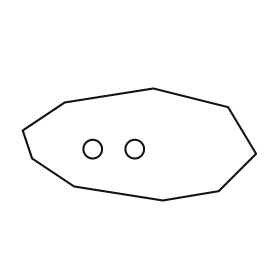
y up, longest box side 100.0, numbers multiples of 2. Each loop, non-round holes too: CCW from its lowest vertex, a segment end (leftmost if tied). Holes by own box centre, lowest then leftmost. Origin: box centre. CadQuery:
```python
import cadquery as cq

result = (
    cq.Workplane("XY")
    .moveTo(10.0, -24.0)
    .lineTo(34.0, -20.0)
    .lineTo(50.0, -4.0)
    .lineTo(38.0, 16.0)
    .lineTo(6.0, 24.0)
    .lineTo(-32.0, 18.0)
    .lineTo(-50.0, 6.0)
    .lineTo(-46.0, -6.0)
    .lineTo(-28.0, -18.0)
    .close()
    .moveTo(-20.0, -2.0)
    .circle(4.0)
    .moveTo(-2.0, -2.0)
    .circle(4.0)
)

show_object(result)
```